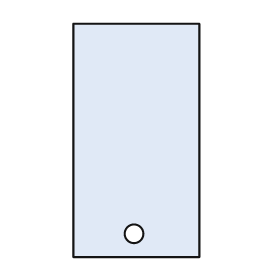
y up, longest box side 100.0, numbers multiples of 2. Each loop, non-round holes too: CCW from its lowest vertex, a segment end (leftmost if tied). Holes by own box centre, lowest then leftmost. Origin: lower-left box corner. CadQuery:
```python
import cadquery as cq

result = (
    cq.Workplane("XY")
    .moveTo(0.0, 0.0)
    .lineTo(54.0, 0.0)
    .lineTo(54.0, 100.0)
    .lineTo(0.0, 100.0)
    .close()
    .moveTo(26.0, 10.0)
    .circle(4.0)
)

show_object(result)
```